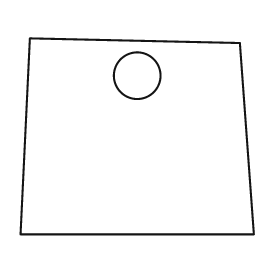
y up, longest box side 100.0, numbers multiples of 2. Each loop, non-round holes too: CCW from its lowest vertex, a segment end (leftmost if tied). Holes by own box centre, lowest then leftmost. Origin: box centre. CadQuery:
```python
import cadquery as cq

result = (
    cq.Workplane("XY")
    .moveTo(-50.0, -42.0)
    .lineTo(50.0, -42.0)
    .lineTo(44.0, 40.0)
    .lineTo(-46.0, 42.0)
    .close()
    .moveTo(0.0, 26.0)
    .circle(10.0)
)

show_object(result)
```